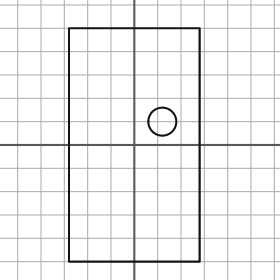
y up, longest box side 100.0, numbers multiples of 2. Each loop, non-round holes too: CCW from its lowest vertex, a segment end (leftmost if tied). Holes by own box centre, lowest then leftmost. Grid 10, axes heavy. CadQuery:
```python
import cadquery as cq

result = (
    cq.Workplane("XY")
    .moveTo(-28.0, -50.0)
    .lineTo(28.0, -50.0)
    .lineTo(28.0, 50.0)
    .lineTo(-28.0, 50.0)
    .close()
    .moveTo(12.0, 10.0)
    .circle(6.0)
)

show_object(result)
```